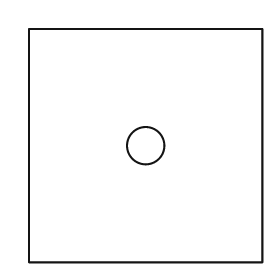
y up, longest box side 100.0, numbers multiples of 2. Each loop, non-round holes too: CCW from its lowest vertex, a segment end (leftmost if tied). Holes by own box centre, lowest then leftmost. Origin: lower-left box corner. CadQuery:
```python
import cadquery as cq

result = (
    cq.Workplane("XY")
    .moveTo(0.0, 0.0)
    .lineTo(100.0, 0.0)
    .lineTo(100.0, 100.0)
    .lineTo(0.0, 100.0)
    .close()
    .moveTo(50.0, 50.0)
    .circle(8.0)
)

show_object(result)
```